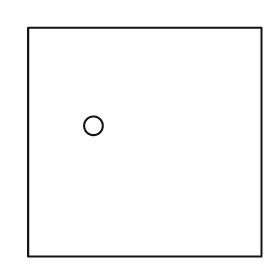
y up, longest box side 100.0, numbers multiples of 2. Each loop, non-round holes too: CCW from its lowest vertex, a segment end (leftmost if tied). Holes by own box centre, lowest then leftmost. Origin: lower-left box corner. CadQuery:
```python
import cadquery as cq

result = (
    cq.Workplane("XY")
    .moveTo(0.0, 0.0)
    .lineTo(100.0, 0.0)
    .lineTo(100.0, 98.0)
    .lineTo(0.0, 98.0)
    .close()
    .moveTo(28.0, 56.0)
    .circle(4.0)
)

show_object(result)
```